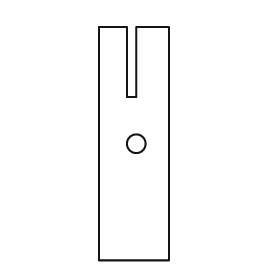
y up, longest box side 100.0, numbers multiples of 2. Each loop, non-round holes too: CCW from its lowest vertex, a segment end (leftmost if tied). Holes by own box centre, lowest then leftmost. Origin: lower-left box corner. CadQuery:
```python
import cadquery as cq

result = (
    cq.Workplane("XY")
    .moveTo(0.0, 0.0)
    .lineTo(30.0, 0.0)
    .lineTo(30.0, 100.0)
    .lineTo(16.0, 100.0)
    .lineTo(16.0, 70.0)
    .lineTo(12.0, 70.0)
    .lineTo(12.0, 100.0)
    .lineTo(0.0, 100.0)
    .close()
    .moveTo(16.0, 50.0)
    .circle(4.0)
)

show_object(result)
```